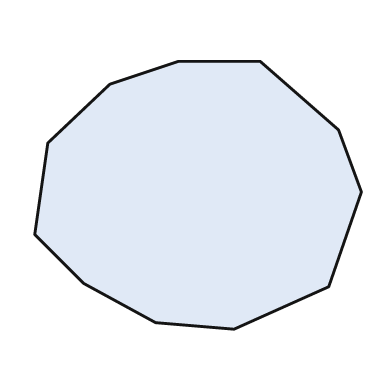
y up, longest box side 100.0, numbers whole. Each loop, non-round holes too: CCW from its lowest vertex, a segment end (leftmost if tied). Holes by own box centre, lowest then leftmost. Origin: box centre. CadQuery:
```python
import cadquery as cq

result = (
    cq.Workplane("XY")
    .moveTo(11.0, -41.0)
    .lineTo(40.0, -28.0)
    .lineTo(50.0, 1.0)
    .lineTo(43.0, 20.0)
    .lineTo(19.0, 41.0)
    .lineTo(-6.0, 41.0)
    .lineTo(-27.0, 34.0)
    .lineTo(-46.0, 16.0)
    .lineTo(-50.0, -12.0)
    .lineTo(-35.0, -27.0)
    .lineTo(-13.0, -39.0)
    .close()
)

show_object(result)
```